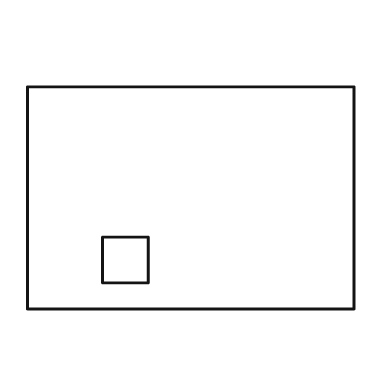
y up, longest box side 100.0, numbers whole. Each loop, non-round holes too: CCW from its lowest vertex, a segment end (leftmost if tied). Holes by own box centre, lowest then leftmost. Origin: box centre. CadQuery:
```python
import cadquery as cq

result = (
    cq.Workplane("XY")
    .moveTo(-50.0, -34.0)
    .lineTo(50.0, -34.0)
    .lineTo(50.0, 34.0)
    .lineTo(-50.0, 34.0)
    .close()
    .moveTo(-27.0, -26.0)
    .lineTo(-13.0, -26.0)
    .lineTo(-13.0, -12.0)
    .lineTo(-27.0, -12.0)
    .close()
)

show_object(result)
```